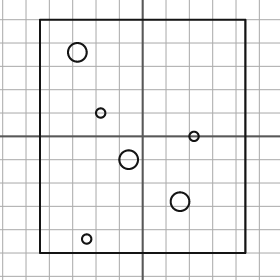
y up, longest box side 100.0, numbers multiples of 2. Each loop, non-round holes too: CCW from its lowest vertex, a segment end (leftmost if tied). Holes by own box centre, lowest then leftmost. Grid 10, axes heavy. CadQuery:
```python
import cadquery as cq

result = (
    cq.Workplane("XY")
    .moveTo(-44.0, -50.0)
    .lineTo(44.0, -50.0)
    .lineTo(44.0, 50.0)
    .lineTo(-44.0, 50.0)
    .close()
    .moveTo(-24.0, -44.0)
    .circle(2.0)
    .moveTo(16.0, -28.0)
    .circle(4.0)
    .moveTo(-6.0, -10.0)
    .circle(4.0)
    .moveTo(22.0, 0.0)
    .circle(2.0)
    .moveTo(-18.0, 10.0)
    .circle(2.0)
    .moveTo(-28.0, 36.0)
    .circle(4.0)
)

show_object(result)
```